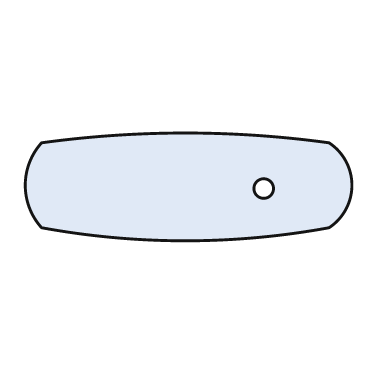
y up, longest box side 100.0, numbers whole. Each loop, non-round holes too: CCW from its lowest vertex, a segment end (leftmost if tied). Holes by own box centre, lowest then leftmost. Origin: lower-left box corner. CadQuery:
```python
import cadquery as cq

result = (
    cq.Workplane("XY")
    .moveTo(5.0, 4.0)
    .threePointArc((49.0, 0.0), (93.0, 4.0))
    .threePointArc((100.0, 17.0), (93.0, 30.0))
    .threePointArc((49.0, 33.0), (5.0, 30.0))
    .threePointArc((0.0, 17.0), (5.0, 4.0))
    .close()
    .moveTo(73.0, 16.0)
    .circle(3.0)
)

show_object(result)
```